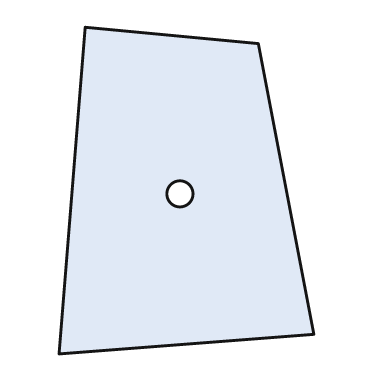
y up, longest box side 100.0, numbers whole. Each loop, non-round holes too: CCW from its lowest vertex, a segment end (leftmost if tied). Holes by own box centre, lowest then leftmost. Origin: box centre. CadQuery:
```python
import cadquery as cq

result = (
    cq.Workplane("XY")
    .moveTo(-39.0, -50.0)
    .lineTo(39.0, -44.0)
    .lineTo(22.0, 45.0)
    .lineTo(-31.0, 50.0)
    .close()
    .moveTo(-2.0, -1.0)
    .circle(4.0)
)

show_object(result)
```